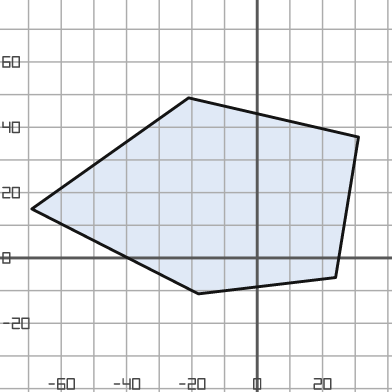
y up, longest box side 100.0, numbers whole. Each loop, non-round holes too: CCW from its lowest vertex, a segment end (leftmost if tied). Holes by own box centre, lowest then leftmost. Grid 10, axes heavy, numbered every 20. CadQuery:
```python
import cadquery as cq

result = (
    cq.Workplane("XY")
    .moveTo(-18.0, -11.0)
    .lineTo(24.0, -6.0)
    .lineTo(31.0, 37.0)
    .lineTo(-21.0, 49.0)
    .lineTo(-69.0, 15.0)
    .close()
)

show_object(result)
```